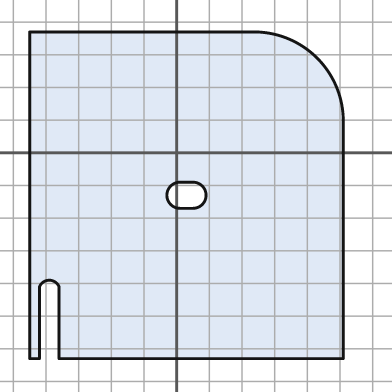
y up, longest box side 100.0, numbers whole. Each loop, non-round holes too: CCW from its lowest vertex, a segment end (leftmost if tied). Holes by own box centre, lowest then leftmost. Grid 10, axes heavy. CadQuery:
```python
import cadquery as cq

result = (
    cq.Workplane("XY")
    .moveTo(-45.0, -63.0)
    .lineTo(-42.0, -63.0)
    .lineTo(-42.0, -41.0)
    .threePointArc((-39.0, -39.0), (-36.0, -41.0))
    .lineTo(-36.0, -63.0)
    .lineTo(51.0, -63.0)
    .lineTo(51.0, 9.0)
    .threePointArc((43.0, 29.0), (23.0, 37.0))
    .lineTo(-45.0, 37.0)
    .close()
    .moveTo(1.0, -17.0)
    .lineTo(5.0, -17.0)
    .threePointArc((9.0, -13.0), (5.0, -9.0))
    .lineTo(1.0, -9.0)
    .threePointArc((-3.0, -13.0), (1.0, -17.0))
    .close()
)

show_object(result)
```